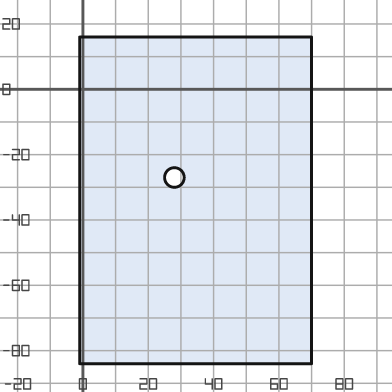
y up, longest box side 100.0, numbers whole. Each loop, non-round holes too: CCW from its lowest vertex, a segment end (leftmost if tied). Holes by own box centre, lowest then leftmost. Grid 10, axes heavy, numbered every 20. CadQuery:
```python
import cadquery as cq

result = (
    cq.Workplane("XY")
    .moveTo(-1.0, -84.0)
    .lineTo(70.0, -84.0)
    .lineTo(70.0, 16.0)
    .lineTo(-1.0, 16.0)
    .close()
    .moveTo(28.0, -27.0)
    .circle(3.0)
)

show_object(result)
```